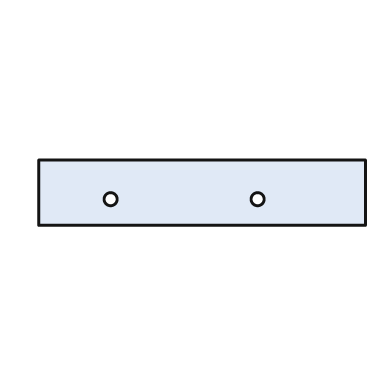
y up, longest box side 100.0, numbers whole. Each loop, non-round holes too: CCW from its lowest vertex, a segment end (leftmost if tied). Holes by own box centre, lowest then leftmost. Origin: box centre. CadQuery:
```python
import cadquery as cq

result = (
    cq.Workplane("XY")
    .moveTo(-50.0, -10.0)
    .lineTo(50.0, -10.0)
    .lineTo(50.0, 10.0)
    .lineTo(-50.0, 10.0)
    .close()
    .moveTo(-28.0, -2.0)
    .circle(2.0)
    .moveTo(17.0, -2.0)
    .circle(2.0)
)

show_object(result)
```